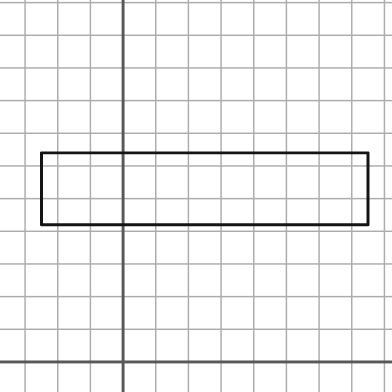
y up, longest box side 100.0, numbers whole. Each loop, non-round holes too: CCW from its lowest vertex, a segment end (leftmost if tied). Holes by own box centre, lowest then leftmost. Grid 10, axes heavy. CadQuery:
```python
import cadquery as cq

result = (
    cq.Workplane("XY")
    .moveTo(-25.0, 42.0)
    .lineTo(75.0, 42.0)
    .lineTo(75.0, 64.0)
    .lineTo(-25.0, 64.0)
    .close()
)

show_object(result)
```